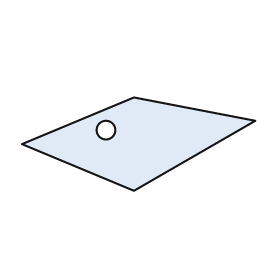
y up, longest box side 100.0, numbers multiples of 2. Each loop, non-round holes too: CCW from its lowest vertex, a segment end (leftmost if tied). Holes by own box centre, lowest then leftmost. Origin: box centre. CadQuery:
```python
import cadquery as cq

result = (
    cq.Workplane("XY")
    .moveTo(-2.0, -20.0)
    .lineTo(50.0, 10.0)
    .lineTo(-2.0, 20.0)
    .lineTo(-50.0, 0.0)
    .close()
    .moveTo(-14.0, 6.0)
    .circle(4.0)
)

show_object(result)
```